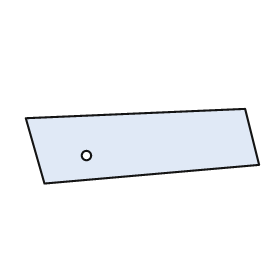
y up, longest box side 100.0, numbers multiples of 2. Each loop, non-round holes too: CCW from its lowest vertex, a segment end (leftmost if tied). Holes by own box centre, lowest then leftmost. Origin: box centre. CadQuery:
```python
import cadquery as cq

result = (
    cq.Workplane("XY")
    .moveTo(-42.0, -16.0)
    .lineTo(50.0, -8.0)
    .lineTo(44.0, 16.0)
    .lineTo(-50.0, 12.0)
    .close()
    .moveTo(-24.0, -4.0)
    .circle(2.0)
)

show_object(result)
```